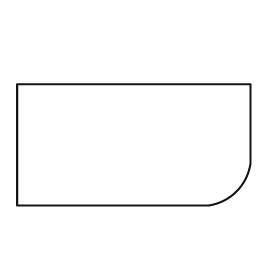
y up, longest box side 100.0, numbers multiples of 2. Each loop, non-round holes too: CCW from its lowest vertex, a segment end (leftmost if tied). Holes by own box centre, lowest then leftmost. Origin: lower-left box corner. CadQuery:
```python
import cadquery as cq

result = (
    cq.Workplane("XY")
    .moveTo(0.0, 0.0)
    .lineTo(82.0, 0.0)
    .threePointArc((94.0, 6.0), (100.0, 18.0))
    .lineTo(100.0, 52.0)
    .lineTo(0.0, 52.0)
    .close()
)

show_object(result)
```